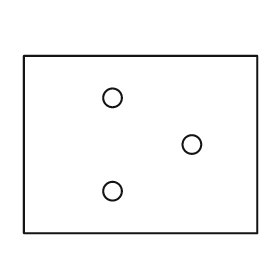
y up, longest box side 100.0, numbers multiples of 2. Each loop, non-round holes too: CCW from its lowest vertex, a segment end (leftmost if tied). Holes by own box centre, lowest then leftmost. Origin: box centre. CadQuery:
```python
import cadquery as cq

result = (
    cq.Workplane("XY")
    .moveTo(-50.0, -38.0)
    .lineTo(50.0, -38.0)
    .lineTo(50.0, 38.0)
    .lineTo(-50.0, 38.0)
    .close()
    .moveTo(-12.0, -20.0)
    .circle(4.0)
    .moveTo(22.0, 0.0)
    .circle(4.0)
    .moveTo(-12.0, 20.0)
    .circle(4.0)
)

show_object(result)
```